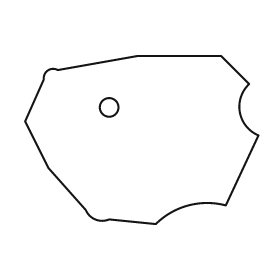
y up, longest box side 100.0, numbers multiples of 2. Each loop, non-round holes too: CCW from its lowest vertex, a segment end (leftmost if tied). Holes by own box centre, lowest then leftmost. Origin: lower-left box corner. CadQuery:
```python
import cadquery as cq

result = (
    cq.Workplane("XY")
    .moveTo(56.0, 0.0)
    .threePointArc((70.0, 8.0), (86.0, 8.0))
    .lineTo(100.0, 38.0)
    .threePointArc((92.0, 48.0), (96.0, 60.0))
    .lineTo(84.0, 72.0)
    .lineTo(48.0, 72.0)
    .lineTo(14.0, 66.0)
    .threePointArc((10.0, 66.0), (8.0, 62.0))
    .lineTo(0.0, 44.0)
    .lineTo(10.0, 24.0)
    .lineTo(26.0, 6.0)
    .threePointArc((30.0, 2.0), (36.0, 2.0))
    .close()
    .moveTo(36.0, 50.0)
    .circle(4.0)
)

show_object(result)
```